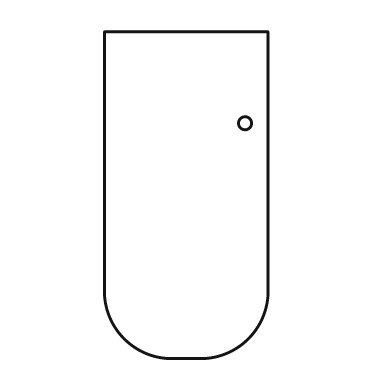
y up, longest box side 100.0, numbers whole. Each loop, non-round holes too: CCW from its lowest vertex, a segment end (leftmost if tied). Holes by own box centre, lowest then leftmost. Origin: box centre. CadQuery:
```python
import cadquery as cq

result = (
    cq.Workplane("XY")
    .moveTo(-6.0, -50.0)
    .lineTo(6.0, -50.0)
    .threePointArc((19.0, -44.0), (25.0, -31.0))
    .lineTo(25.0, 50.0)
    .lineTo(-25.0, 50.0)
    .lineTo(-25.0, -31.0)
    .threePointArc((-19.0, -44.0), (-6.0, -50.0))
    .close()
    .moveTo(18.0, 22.0)
    .circle(2.0)
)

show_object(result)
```